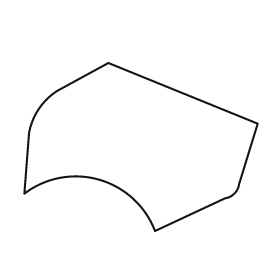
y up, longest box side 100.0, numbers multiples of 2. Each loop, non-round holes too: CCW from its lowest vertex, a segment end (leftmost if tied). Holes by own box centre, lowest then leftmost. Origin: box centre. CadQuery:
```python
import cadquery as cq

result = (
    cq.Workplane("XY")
    .moveTo(6.0, -36.0)
    .lineTo(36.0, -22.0)
    .threePointArc((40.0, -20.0), (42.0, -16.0))
    .lineTo(50.0, 10.0)
    .lineTo(-14.0, 36.0)
    .lineTo(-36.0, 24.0)
    .threePointArc((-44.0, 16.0), (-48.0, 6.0))
    .lineTo(-50.0, -20.0)
    .threePointArc((-18.0, -14.0), (6.0, -36.0))
    .close()
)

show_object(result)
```